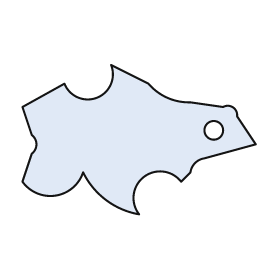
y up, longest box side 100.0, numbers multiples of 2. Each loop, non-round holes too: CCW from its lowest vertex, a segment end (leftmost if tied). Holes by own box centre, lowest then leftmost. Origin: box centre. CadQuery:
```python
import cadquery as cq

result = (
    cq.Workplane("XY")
    .moveTo(0.0, -32.0)
    .threePointArc((2.0, -16.0), (18.0, -18.0))
    .lineTo(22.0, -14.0)
    .threePointArc((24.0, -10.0), (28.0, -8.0))
    .lineTo(50.0, -2.0)
    .lineTo(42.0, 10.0)
    .threePointArc((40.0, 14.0), (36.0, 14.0))
    .lineTo(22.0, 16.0)
    .threePointArc((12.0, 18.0), (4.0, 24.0))
    .lineTo(-12.0, 32.0)
    .threePointArc((-18.0, 18.0), (-32.0, 24.0))
    .lineTo(-50.0, 14.0)
    .lineTo(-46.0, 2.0)
    .threePointArc((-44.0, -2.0), (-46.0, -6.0))
    .lineTo(-50.0, -18.0)
    .threePointArc((-36.0, -24.0), (-24.0, -14.0))
    .threePointArc((-14.0, -26.0), (0.0, -32.0))
    .close()
    .moveTo(32.0, 4.0)
    .circle(4.0)
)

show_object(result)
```